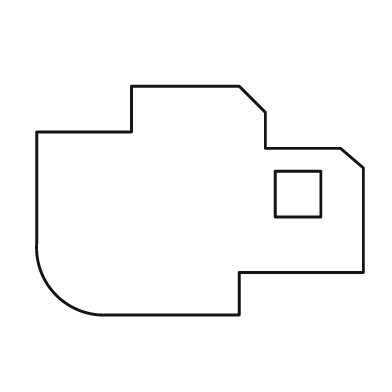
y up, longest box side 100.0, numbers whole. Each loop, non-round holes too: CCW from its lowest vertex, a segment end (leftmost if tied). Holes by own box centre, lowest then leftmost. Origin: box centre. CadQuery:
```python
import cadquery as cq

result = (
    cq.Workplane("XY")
    .moveTo(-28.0, -35.0)
    .lineTo(12.0, -35.0)
    .lineTo(12.0, -22.0)
    .lineTo(50.0, -22.0)
    .lineTo(50.0, 10.0)
    .lineTo(43.0, 16.0)
    .lineTo(20.0, 16.0)
    .lineTo(20.0, 27.0)
    .lineTo(12.0, 35.0)
    .lineTo(-21.0, 35.0)
    .lineTo(-21.0, 21.0)
    .lineTo(-50.0, 21.0)
    .lineTo(-50.0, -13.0)
    .threePointArc((-44.0, -29.0), (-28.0, -35.0))
    .close()
    .moveTo(23.0, -5.0)
    .lineTo(37.0, -5.0)
    .lineTo(37.0, 9.0)
    .lineTo(23.0, 9.0)
    .close()
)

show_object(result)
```